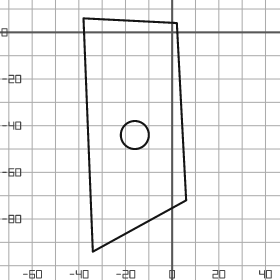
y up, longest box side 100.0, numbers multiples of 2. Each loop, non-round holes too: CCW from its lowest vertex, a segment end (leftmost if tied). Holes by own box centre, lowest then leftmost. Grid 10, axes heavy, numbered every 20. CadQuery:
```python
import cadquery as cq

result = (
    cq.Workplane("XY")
    .moveTo(-34.0, -94.0)
    .lineTo(6.0, -72.0)
    .lineTo(2.0, 4.0)
    .lineTo(-38.0, 6.0)
    .close()
    .moveTo(-16.0, -44.0)
    .circle(6.0)
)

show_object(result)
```